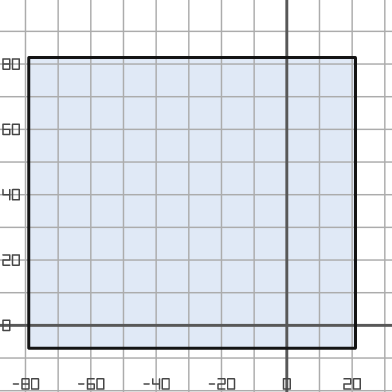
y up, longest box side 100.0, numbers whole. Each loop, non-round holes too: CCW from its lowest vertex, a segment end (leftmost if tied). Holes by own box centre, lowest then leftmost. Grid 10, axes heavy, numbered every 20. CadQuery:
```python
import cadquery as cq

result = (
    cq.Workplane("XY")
    .moveTo(-79.0, -7.0)
    .lineTo(21.0, -7.0)
    .lineTo(21.0, 82.0)
    .lineTo(-79.0, 82.0)
    .close()
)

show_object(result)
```